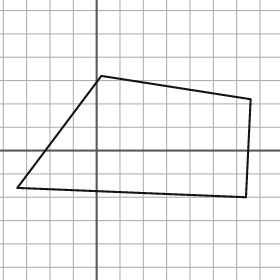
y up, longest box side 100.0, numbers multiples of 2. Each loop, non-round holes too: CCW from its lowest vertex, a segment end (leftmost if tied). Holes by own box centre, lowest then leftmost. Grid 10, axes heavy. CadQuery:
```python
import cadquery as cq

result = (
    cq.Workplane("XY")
    .moveTo(64.0, -20.0)
    .lineTo(66.0, 22.0)
    .lineTo(2.0, 32.0)
    .lineTo(-34.0, -16.0)
    .close()
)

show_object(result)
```